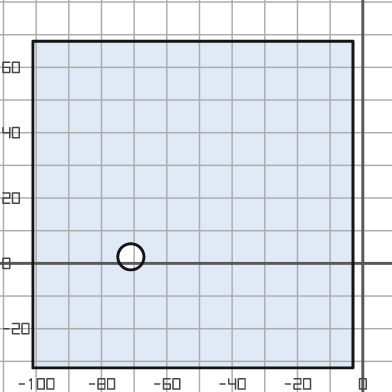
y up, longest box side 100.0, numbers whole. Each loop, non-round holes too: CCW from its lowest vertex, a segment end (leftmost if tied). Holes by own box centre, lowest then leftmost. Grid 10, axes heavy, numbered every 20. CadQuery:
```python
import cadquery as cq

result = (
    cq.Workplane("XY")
    .moveTo(-101.0, -32.0)
    .lineTo(-3.0, -32.0)
    .lineTo(-3.0, 68.0)
    .lineTo(-101.0, 68.0)
    .close()
    .moveTo(-71.0, 2.0)
    .circle(4.0)
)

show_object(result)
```